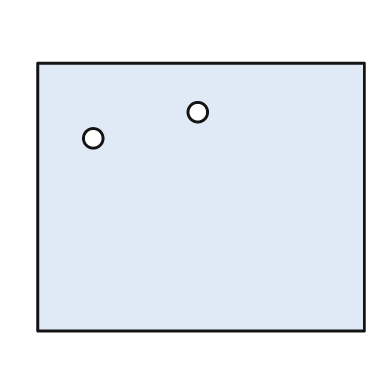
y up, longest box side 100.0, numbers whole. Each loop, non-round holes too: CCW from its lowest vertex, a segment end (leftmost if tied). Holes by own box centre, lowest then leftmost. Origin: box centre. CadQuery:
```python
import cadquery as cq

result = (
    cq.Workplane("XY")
    .moveTo(-50.0, -41.0)
    .lineTo(50.0, -41.0)
    .lineTo(50.0, 41.0)
    .lineTo(-50.0, 41.0)
    .close()
    .moveTo(-33.0, 18.0)
    .circle(3.0)
    .moveTo(-1.0, 26.0)
    .circle(3.0)
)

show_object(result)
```